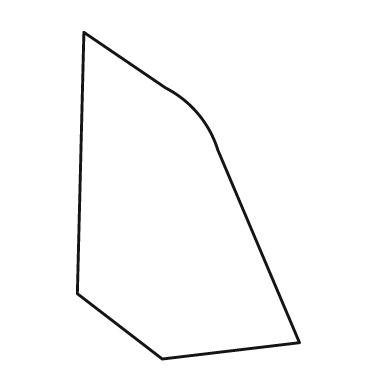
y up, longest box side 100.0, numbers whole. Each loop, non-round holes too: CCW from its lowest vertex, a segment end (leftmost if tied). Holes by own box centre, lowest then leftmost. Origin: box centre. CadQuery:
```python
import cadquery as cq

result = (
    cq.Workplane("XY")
    .moveTo(-8.0, -50.0)
    .lineTo(34.0, -45.0)
    .lineTo(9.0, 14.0)
    .threePointArc((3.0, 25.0), (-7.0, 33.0))
    .lineTo(-32.0, 50.0)
    .lineTo(-34.0, -30.0)
    .close()
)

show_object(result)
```